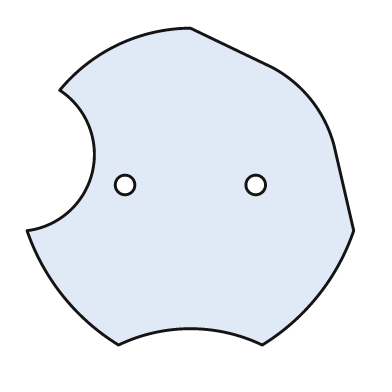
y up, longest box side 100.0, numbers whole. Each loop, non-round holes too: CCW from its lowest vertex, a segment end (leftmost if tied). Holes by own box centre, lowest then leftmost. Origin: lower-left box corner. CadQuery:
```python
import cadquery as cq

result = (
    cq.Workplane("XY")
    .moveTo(28.0, 0.0)
    .threePointArc((50.0, 5.0), (72.0, 0.0))
    .threePointArc((89.0, 15.0), (100.0, 35.0))
    .lineTo(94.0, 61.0)
    .threePointArc((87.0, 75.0), (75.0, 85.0))
    .lineTo(50.0, 97.0)
    .threePointArc((28.0, 92.0), (10.0, 78.0))
    .threePointArc((20.0, 53.0), (0.0, 35.0))
    .threePointArc((11.0, 15.0), (28.0, 0.0))
    .close()
    .moveTo(30.0, 49.0)
    .circle(3.0)
    .moveTo(70.0, 49.0)
    .circle(3.0)
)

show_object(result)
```